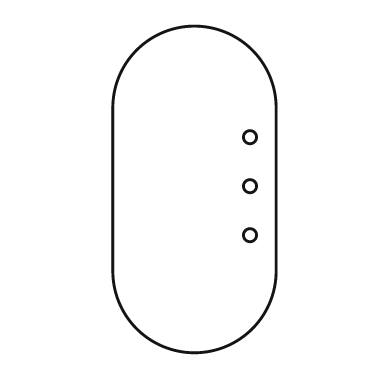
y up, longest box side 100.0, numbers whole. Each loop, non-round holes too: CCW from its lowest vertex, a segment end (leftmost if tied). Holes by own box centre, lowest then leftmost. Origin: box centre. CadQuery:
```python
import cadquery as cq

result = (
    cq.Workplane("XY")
    .moveTo(-25.0, -25.0)
    .threePointArc((0.0, -50.0), (25.0, -25.0))
    .lineTo(25.0, 25.0)
    .threePointArc((0.0, 50.0), (-25.0, 25.0))
    .close()
    .moveTo(17.0, -14.0)
    .circle(2.0)
    .moveTo(17.0, 1.0)
    .circle(2.0)
    .moveTo(17.0, 16.0)
    .circle(2.0)
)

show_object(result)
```